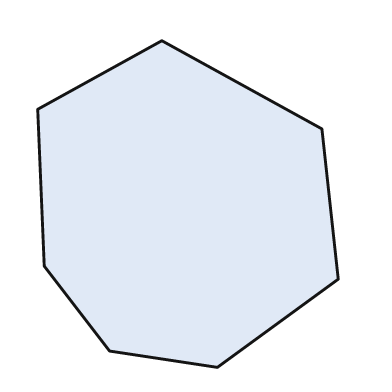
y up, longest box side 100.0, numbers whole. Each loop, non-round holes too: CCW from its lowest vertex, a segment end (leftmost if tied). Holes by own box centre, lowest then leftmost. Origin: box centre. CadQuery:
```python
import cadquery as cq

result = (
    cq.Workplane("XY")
    .moveTo(9.0, -50.0)
    .lineTo(46.0, -23.0)
    .lineTo(41.0, 23.0)
    .lineTo(-8.0, 50.0)
    .lineTo(-46.0, 29.0)
    .lineTo(-44.0, -19.0)
    .lineTo(-24.0, -45.0)
    .close()
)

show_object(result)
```